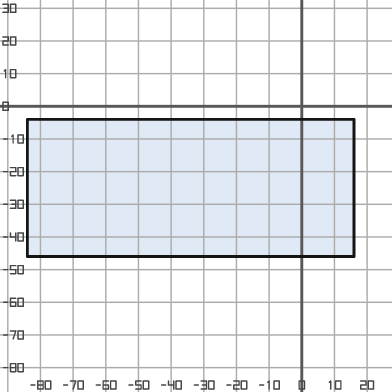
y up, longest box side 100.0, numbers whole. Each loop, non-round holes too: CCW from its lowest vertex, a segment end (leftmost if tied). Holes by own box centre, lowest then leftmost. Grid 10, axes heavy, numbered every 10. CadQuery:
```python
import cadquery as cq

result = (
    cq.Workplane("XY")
    .moveTo(-84.0, -46.0)
    .lineTo(16.0, -46.0)
    .lineTo(16.0, -4.0)
    .lineTo(-84.0, -4.0)
    .close()
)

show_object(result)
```